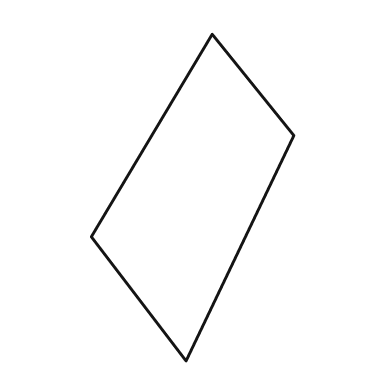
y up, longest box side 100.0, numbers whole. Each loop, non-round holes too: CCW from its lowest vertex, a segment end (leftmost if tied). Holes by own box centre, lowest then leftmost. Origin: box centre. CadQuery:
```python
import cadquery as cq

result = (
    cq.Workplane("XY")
    .moveTo(-2.0, -50.0)
    .lineTo(31.0, 19.0)
    .lineTo(6.0, 50.0)
    .lineTo(-31.0, -12.0)
    .close()
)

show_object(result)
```